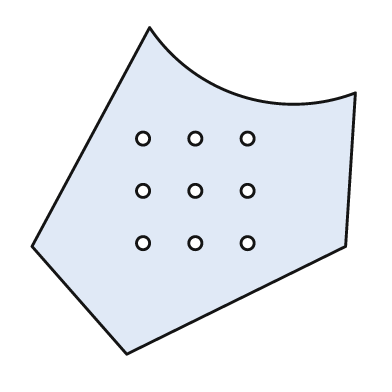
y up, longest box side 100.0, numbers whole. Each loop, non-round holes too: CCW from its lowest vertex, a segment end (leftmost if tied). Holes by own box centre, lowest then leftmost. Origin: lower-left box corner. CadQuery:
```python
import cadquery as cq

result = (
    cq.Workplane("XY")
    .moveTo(29.0, 0.0)
    .lineTo(96.0, 33.0)
    .lineTo(99.0, 80.0)
    .threePointArc((64.0, 79.0), (36.0, 100.0))
    .lineTo(0.0, 33.0)
    .close()
    .moveTo(34.0, 34.0)
    .circle(2.0)
    .moveTo(50.0, 34.0)
    .circle(2.0)
    .moveTo(66.0, 34.0)
    .circle(2.0)
    .moveTo(34.0, 50.0)
    .circle(2.0)
    .moveTo(50.0, 50.0)
    .circle(2.0)
    .moveTo(66.0, 50.0)
    .circle(2.0)
    .moveTo(34.0, 66.0)
    .circle(2.0)
    .moveTo(50.0, 66.0)
    .circle(2.0)
    .moveTo(66.0, 66.0)
    .circle(2.0)
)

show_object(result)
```